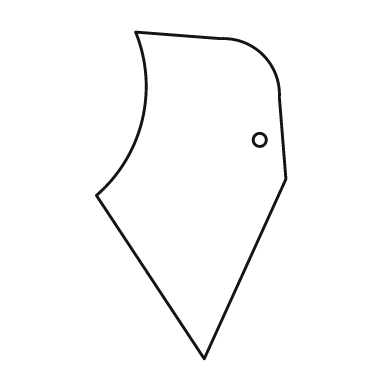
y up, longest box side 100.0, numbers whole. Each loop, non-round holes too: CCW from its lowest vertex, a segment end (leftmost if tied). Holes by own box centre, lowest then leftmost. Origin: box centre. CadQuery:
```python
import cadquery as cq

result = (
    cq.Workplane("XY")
    .moveTo(4.0, -50.0)
    .lineTo(29.0, 5.0)
    .lineTo(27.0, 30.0)
    .threePointArc((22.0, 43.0), (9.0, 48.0))
    .lineTo(-17.0, 50.0)
    .threePointArc((-15.0, 23.0), (-29.0, 0.0))
    .close()
    .moveTo(21.0, 17.0)
    .circle(2.0)
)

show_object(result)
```